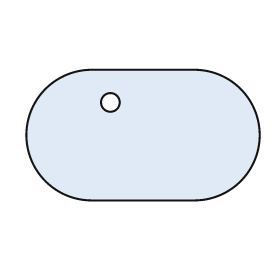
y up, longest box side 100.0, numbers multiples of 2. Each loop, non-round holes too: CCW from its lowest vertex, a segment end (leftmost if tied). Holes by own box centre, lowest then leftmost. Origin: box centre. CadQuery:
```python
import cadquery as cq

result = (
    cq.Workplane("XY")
    .moveTo(-22.0, -28.0)
    .lineTo(22.0, -28.0)
    .threePointArc((50.0, 0.0), (22.0, 28.0))
    .lineTo(-22.0, 28.0)
    .threePointArc((-50.0, 0.0), (-22.0, -28.0))
    .close()
    .moveTo(-14.0, 14.0)
    .circle(4.0)
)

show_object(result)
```